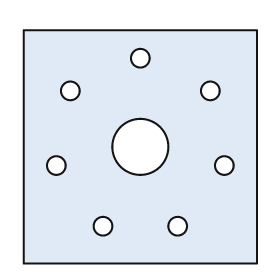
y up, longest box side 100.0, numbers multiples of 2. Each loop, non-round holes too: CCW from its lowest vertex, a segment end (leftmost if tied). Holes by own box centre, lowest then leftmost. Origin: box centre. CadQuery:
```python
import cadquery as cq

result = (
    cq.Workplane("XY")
    .moveTo(-50.0, -50.0)
    .lineTo(50.0, -50.0)
    .lineTo(50.0, 50.0)
    .lineTo(-50.0, 50.0)
    .close()
    .moveTo(-16.0, -34.0)
    .circle(4.0)
    .moveTo(16.0, -34.0)
    .circle(4.0)
    .moveTo(-36.0, -8.0)
    .circle(4.0)
    .moveTo(36.0, -8.0)
    .circle(4.0)
    .moveTo(0.0, 0.0)
    .circle(12.0)
    .moveTo(-30.0, 24.0)
    .circle(4.0)
    .moveTo(30.0, 24.0)
    .circle(4.0)
    .moveTo(0.0, 38.0)
    .circle(4.0)
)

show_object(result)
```